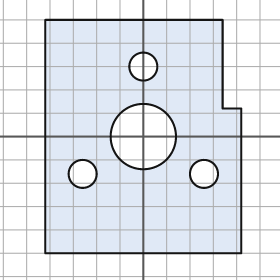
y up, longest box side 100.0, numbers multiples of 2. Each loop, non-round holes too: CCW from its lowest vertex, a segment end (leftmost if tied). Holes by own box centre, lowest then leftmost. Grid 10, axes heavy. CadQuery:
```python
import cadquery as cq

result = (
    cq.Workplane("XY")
    .moveTo(-42.0, -50.0)
    .lineTo(42.0, -50.0)
    .lineTo(42.0, 12.0)
    .lineTo(34.0, 12.0)
    .lineTo(34.0, 50.0)
    .lineTo(-42.0, 50.0)
    .close()
    .moveTo(-26.0, -16.0)
    .circle(6.0)
    .moveTo(26.0, -16.0)
    .circle(6.0)
    .moveTo(0.0, 0.0)
    .circle(14.0)
    .moveTo(0.0, 30.0)
    .circle(6.0)
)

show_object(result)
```